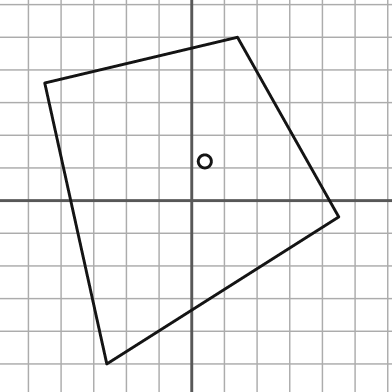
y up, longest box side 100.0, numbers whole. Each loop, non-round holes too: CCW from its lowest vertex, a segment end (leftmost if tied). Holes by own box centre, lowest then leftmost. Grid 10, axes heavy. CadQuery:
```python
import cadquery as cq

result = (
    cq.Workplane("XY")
    .moveTo(-26.0, -50.0)
    .lineTo(45.0, -5.0)
    .lineTo(14.0, 50.0)
    .lineTo(-45.0, 36.0)
    .close()
    .moveTo(4.0, 12.0)
    .circle(2.0)
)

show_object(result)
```